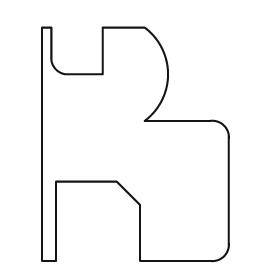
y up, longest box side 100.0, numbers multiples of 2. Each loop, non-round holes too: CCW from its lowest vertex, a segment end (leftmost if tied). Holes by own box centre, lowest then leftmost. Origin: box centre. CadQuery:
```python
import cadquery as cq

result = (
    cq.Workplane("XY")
    .moveTo(-40.0, -50.0)
    .lineTo(-34.0, -50.0)
    .lineTo(-34.0, -16.0)
    .lineTo(-8.0, -16.0)
    .lineTo(2.0, -26.0)
    .lineTo(2.0, -50.0)
    .lineTo(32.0, -50.0)
    .threePointArc((38.0, -48.0), (40.0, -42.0))
    .lineTo(40.0, 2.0)
    .threePointArc((38.0, 8.0), (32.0, 10.0))
    .lineTo(4.0, 10.0)
    .threePointArc((14.0, 30.0), (4.0, 50.0))
    .lineTo(-14.0, 50.0)
    .lineTo(-14.0, 30.0)
    .lineTo(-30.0, 30.0)
    .threePointArc((-34.0, 32.0), (-36.0, 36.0))
    .lineTo(-36.0, 50.0)
    .lineTo(-40.0, 50.0)
    .close()
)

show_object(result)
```